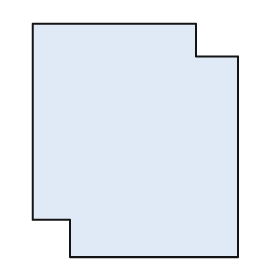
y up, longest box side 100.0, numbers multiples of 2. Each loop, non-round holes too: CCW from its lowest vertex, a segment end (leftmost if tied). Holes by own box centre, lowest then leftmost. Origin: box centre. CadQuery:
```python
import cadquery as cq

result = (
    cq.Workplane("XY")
    .moveTo(-28.0, -50.0)
    .lineTo(44.0, -50.0)
    .lineTo(44.0, 36.0)
    .lineTo(26.0, 36.0)
    .lineTo(26.0, 50.0)
    .lineTo(-44.0, 50.0)
    .lineTo(-44.0, -34.0)
    .lineTo(-28.0, -34.0)
    .close()
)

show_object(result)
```